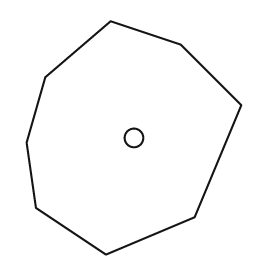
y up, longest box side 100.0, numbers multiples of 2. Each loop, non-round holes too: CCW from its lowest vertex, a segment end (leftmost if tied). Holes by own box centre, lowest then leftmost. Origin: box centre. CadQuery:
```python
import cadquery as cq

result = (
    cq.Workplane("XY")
    .moveTo(-12.0, -50.0)
    .lineTo(26.0, -34.0)
    .lineTo(46.0, 14.0)
    .lineTo(20.0, 40.0)
    .lineTo(-10.0, 50.0)
    .lineTo(-38.0, 26.0)
    .lineTo(-46.0, -2.0)
    .lineTo(-42.0, -30.0)
    .close()
    .moveTo(0.0, 0.0)
    .circle(4.0)
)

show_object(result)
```